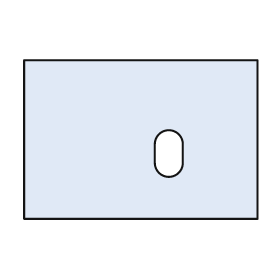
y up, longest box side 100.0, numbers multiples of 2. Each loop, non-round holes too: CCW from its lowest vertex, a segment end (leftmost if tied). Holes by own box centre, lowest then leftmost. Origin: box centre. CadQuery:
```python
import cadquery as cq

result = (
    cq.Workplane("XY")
    .moveTo(-50.0, -34.0)
    .lineTo(50.0, -34.0)
    .lineTo(50.0, 34.0)
    .lineTo(-50.0, 34.0)
    .close()
    .moveTo(6.0, -10.0)
    .threePointArc((12.0, -16.0), (18.0, -10.0))
    .lineTo(18.0, -2.0)
    .threePointArc((12.0, 4.0), (6.0, -2.0))
    .close()
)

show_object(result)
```